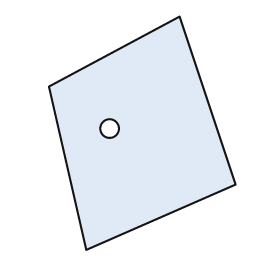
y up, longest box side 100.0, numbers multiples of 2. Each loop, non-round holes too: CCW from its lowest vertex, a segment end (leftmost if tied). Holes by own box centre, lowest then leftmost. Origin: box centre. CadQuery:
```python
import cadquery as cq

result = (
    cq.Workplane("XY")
    .moveTo(-24.0, -50.0)
    .lineTo(40.0, -22.0)
    .lineTo(16.0, 50.0)
    .lineTo(-40.0, 20.0)
    .close()
    .moveTo(-14.0, 2.0)
    .circle(4.0)
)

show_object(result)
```